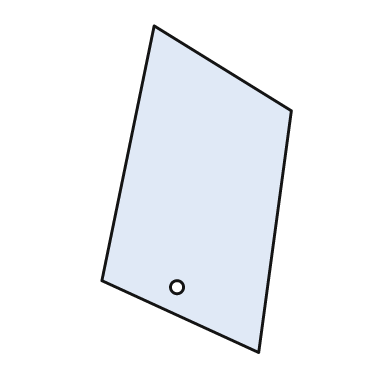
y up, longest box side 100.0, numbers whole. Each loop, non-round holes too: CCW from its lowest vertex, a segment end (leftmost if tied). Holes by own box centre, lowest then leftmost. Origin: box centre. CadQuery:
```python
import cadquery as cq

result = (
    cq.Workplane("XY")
    .moveTo(19.0, -50.0)
    .lineTo(29.0, 24.0)
    .lineTo(-13.0, 50.0)
    .lineTo(-29.0, -28.0)
    .close()
    .moveTo(-6.0, -30.0)
    .circle(2.0)
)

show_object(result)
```